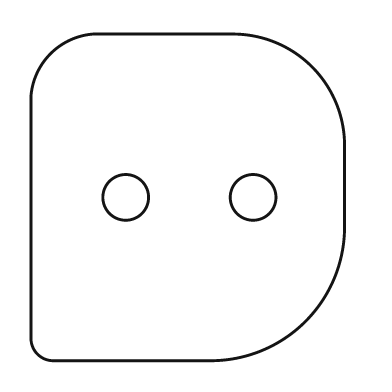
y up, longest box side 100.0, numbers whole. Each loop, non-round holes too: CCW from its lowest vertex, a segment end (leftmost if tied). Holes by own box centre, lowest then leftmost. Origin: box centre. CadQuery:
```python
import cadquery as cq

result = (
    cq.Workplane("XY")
    .moveTo(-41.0, -50.0)
    .lineTo(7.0, -50.0)
    .threePointArc((36.0, -38.0), (48.0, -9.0))
    .lineTo(48.0, 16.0)
    .threePointArc((38.0, 40.0), (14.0, 50.0))
    .lineTo(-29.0, 50.0)
    .threePointArc((-42.0, 44.0), (-48.0, 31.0))
    .lineTo(-48.0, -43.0)
    .threePointArc((-46.0, -48.0), (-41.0, -50.0))
    .close()
    .moveTo(-19.0, 0.0)
    .circle(7.0)
    .moveTo(20.0, 0.0)
    .circle(7.0)
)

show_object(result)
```